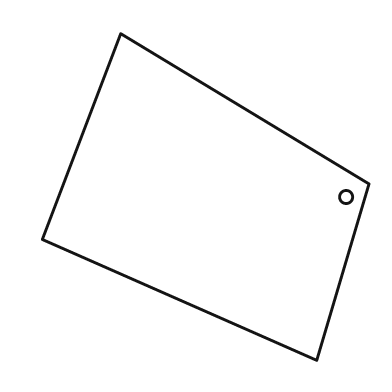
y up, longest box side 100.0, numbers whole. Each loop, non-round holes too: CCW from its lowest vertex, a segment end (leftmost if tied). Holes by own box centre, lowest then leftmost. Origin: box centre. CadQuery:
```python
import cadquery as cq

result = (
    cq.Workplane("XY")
    .moveTo(34.0, -50.0)
    .lineTo(50.0, 4.0)
    .lineTo(-26.0, 50.0)
    .lineTo(-50.0, -13.0)
    .close()
    .moveTo(43.0, 0.0)
    .circle(2.0)
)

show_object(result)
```